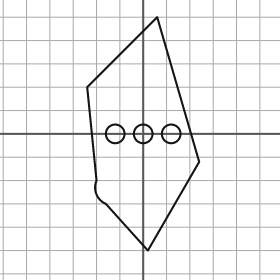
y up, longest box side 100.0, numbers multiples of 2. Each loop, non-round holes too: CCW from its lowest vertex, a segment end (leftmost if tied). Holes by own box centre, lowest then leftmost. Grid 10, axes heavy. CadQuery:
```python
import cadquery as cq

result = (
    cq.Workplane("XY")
    .moveTo(2.0, -50.0)
    .lineTo(24.0, -12.0)
    .lineTo(6.0, 50.0)
    .lineTo(-24.0, 20.0)
    .lineTo(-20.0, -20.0)
    .threePointArc((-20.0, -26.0), (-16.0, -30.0))
    .close()
    .moveTo(-12.0, 0.0)
    .circle(4.0)
    .moveTo(0.0, 0.0)
    .circle(4.0)
    .moveTo(12.0, 0.0)
    .circle(4.0)
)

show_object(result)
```